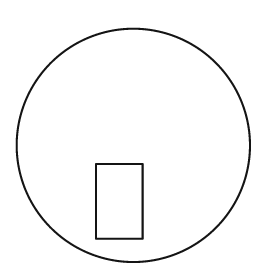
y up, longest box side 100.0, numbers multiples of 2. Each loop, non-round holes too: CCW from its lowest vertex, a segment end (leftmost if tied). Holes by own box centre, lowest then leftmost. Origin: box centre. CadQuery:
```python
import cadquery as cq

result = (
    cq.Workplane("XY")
    .moveTo(0.0, 0.0)
    .circle(50.0)
    .moveTo(-16.0, -40.0)
    .lineTo(4.0, -40.0)
    .lineTo(4.0, -8.0)
    .lineTo(-16.0, -8.0)
    .close()
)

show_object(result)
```